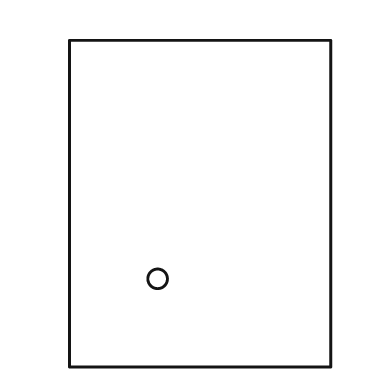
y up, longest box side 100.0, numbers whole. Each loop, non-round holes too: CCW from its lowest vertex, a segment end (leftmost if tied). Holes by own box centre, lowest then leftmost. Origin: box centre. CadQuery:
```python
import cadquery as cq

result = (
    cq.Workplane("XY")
    .moveTo(-40.0, -50.0)
    .lineTo(40.0, -50.0)
    .lineTo(40.0, 50.0)
    .lineTo(-40.0, 50.0)
    .close()
    .moveTo(-13.0, -23.0)
    .circle(3.0)
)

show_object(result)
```